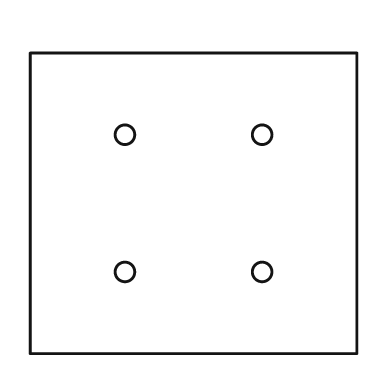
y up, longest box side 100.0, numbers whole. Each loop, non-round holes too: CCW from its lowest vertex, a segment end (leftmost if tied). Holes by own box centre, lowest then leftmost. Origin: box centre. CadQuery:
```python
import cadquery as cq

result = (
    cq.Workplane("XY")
    .moveTo(-50.0, -46.0)
    .lineTo(50.0, -46.0)
    .lineTo(50.0, 46.0)
    .lineTo(-50.0, 46.0)
    .close()
    .moveTo(-21.0, -21.0)
    .circle(3.0)
    .moveTo(21.0, -21.0)
    .circle(3.0)
    .moveTo(-21.0, 21.0)
    .circle(3.0)
    .moveTo(21.0, 21.0)
    .circle(3.0)
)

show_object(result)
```